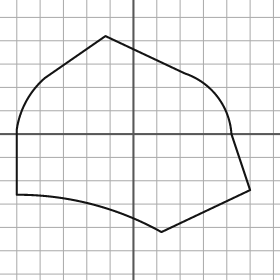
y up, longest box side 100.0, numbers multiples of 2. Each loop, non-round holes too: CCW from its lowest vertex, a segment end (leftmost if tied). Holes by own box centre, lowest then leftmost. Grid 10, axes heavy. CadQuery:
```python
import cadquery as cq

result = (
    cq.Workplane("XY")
    .moveTo(12.0, -42.0)
    .lineTo(50.0, -24.0)
    .lineTo(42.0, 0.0)
    .threePointArc((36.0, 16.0), (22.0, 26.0))
    .lineTo(-12.0, 42.0)
    .lineTo(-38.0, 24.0)
    .threePointArc((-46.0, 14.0), (-50.0, 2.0))
    .lineTo(-50.0, -26.0)
    .threePointArc((-18.0, -30.0), (12.0, -42.0))
    .close()
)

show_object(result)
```